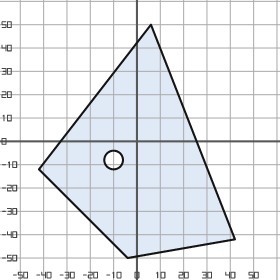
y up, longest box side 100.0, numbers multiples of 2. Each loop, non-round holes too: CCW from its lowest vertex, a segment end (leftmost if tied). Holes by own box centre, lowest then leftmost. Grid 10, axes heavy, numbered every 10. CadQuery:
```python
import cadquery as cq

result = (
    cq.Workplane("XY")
    .moveTo(-4.0, -50.0)
    .lineTo(42.0, -42.0)
    .lineTo(6.0, 50.0)
    .lineTo(-42.0, -12.0)
    .close()
    .moveTo(-10.0, -8.0)
    .circle(4.0)
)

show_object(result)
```